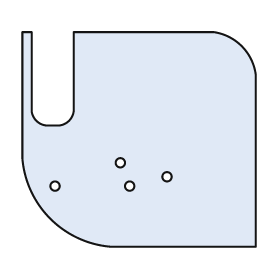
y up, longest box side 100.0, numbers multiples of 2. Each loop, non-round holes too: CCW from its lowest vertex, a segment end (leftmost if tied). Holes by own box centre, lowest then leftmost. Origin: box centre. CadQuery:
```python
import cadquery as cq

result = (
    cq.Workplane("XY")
    .moveTo(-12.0, -46.0)
    .lineTo(50.0, -46.0)
    .lineTo(50.0, 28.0)
    .threePointArc((44.0, 40.0), (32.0, 46.0))
    .lineTo(-28.0, 46.0)
    .lineTo(-28.0, 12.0)
    .threePointArc((-30.0, 8.0), (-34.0, 6.0))
    .lineTo(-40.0, 6.0)
    .threePointArc((-44.0, 8.0), (-46.0, 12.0))
    .lineTo(-46.0, 46.0)
    .lineTo(-50.0, 46.0)
    .lineTo(-50.0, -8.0)
    .threePointArc((-38.0, -34.0), (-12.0, -46.0))
    .close()
    .moveTo(-36.0, -20.0)
    .circle(2.0)
    .moveTo(-4.0, -20.0)
    .circle(2.0)
    .moveTo(12.0, -16.0)
    .circle(2.0)
    .moveTo(-8.0, -10.0)
    .circle(2.0)
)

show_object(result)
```